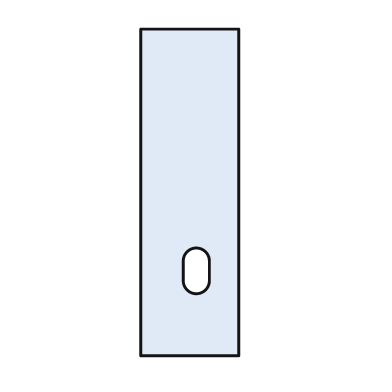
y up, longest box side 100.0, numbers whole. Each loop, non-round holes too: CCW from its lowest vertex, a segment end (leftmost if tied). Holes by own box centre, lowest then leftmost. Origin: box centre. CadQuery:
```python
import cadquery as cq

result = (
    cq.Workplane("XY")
    .moveTo(-15.0, -50.0)
    .lineTo(15.0, -50.0)
    .lineTo(15.0, 50.0)
    .lineTo(-15.0, 50.0)
    .close()
    .moveTo(-2.0, -27.0)
    .threePointArc((2.0, -31.0), (6.0, -27.0))
    .lineTo(6.0, -21.0)
    .threePointArc((2.0, -17.0), (-2.0, -21.0))
    .close()
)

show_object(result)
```